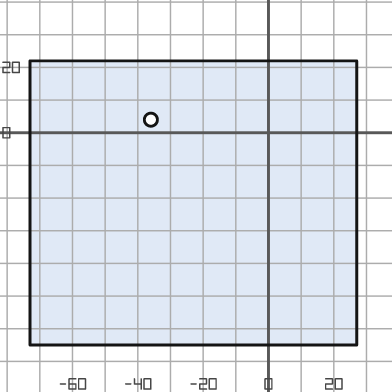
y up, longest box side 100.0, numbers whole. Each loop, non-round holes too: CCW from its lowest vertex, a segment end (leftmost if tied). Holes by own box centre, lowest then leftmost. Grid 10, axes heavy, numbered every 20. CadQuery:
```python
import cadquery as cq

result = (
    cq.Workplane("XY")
    .moveTo(-73.0, -65.0)
    .lineTo(27.0, -65.0)
    .lineTo(27.0, 22.0)
    .lineTo(-73.0, 22.0)
    .close()
    .moveTo(-36.0, 4.0)
    .circle(2.0)
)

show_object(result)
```